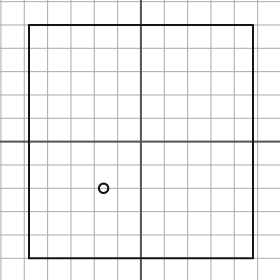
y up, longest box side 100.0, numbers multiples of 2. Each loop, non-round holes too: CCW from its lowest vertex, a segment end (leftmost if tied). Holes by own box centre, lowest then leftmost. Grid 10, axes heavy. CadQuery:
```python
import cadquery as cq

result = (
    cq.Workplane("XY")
    .moveTo(-48.0, -50.0)
    .lineTo(48.0, -50.0)
    .lineTo(48.0, 50.0)
    .lineTo(-48.0, 50.0)
    .close()
    .moveTo(-16.0, -20.0)
    .circle(2.0)
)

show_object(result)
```